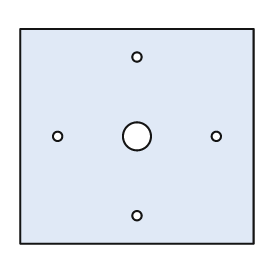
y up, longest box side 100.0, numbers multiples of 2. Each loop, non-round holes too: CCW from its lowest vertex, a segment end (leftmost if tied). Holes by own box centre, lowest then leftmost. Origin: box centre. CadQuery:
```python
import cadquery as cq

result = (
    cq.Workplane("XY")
    .moveTo(-50.0, -46.0)
    .lineTo(50.0, -46.0)
    .lineTo(50.0, 46.0)
    .lineTo(-50.0, 46.0)
    .close()
    .moveTo(0.0, -34.0)
    .circle(2.0)
    .moveTo(-34.0, 0.0)
    .circle(2.0)
    .moveTo(0.0, 0.0)
    .circle(6.0)
    .moveTo(34.0, 0.0)
    .circle(2.0)
    .moveTo(0.0, 34.0)
    .circle(2.0)
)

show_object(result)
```